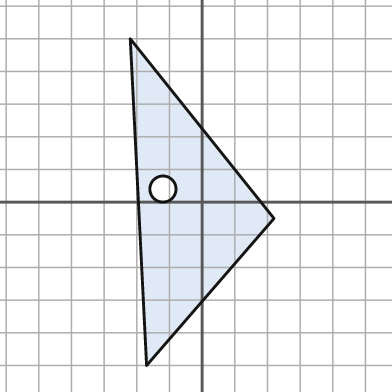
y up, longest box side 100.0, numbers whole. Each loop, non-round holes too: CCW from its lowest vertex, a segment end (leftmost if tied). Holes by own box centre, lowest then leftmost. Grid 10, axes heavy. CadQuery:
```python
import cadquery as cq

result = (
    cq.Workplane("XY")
    .moveTo(-17.0, -50.0)
    .lineTo(22.0, -5.0)
    .lineTo(-22.0, 50.0)
    .close()
    .moveTo(-12.0, 4.0)
    .circle(4.0)
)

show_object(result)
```